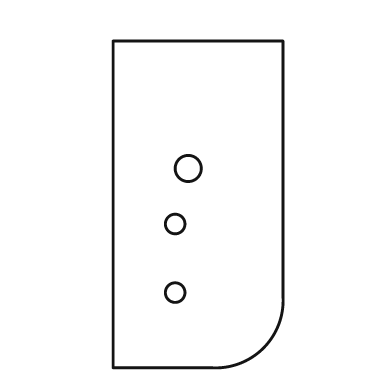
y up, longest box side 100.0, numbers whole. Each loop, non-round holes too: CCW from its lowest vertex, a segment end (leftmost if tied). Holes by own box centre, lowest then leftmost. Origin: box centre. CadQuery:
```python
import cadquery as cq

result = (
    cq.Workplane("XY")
    .moveTo(-26.0, -50.0)
    .lineTo(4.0, -50.0)
    .threePointArc((20.0, -44.0), (26.0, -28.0))
    .lineTo(26.0, 50.0)
    .lineTo(-26.0, 50.0)
    .close()
    .moveTo(-7.0, -27.0)
    .circle(3.0)
    .moveTo(-7.0, -6.0)
    .circle(3.0)
    .moveTo(-3.0, 11.0)
    .circle(4.0)
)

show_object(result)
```